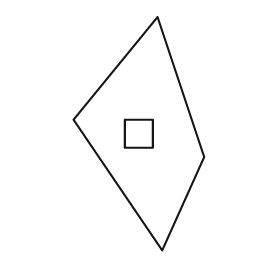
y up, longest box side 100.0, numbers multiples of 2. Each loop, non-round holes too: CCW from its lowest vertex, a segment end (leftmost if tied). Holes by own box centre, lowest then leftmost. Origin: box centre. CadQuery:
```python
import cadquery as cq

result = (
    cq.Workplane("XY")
    .moveTo(10.0, -50.0)
    .lineTo(28.0, -10.0)
    .lineTo(8.0, 50.0)
    .lineTo(-28.0, 6.0)
    .close()
    .moveTo(-6.0, -6.0)
    .lineTo(6.0, -6.0)
    .lineTo(6.0, 6.0)
    .lineTo(-6.0, 6.0)
    .close()
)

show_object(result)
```